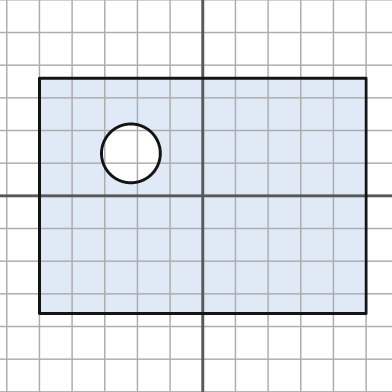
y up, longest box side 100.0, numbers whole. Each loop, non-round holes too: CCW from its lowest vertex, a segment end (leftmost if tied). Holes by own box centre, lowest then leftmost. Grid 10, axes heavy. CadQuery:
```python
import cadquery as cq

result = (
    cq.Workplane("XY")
    .moveTo(-50.0, -36.0)
    .lineTo(50.0, -36.0)
    .lineTo(50.0, 36.0)
    .lineTo(-50.0, 36.0)
    .close()
    .moveTo(-22.0, 13.0)
    .circle(9.0)
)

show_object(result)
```